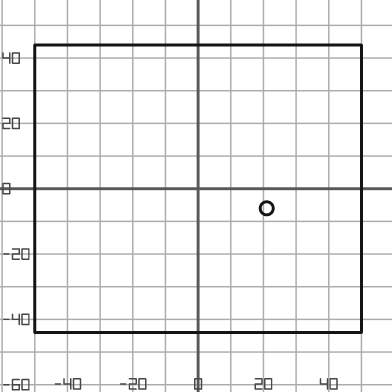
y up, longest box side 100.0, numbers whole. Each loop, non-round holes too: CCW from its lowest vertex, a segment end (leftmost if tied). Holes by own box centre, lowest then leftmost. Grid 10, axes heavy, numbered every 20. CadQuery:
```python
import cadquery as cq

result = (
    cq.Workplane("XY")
    .moveTo(-50.0, -44.0)
    .lineTo(50.0, -44.0)
    .lineTo(50.0, 44.0)
    .lineTo(-50.0, 44.0)
    .close()
    .moveTo(21.0, -6.0)
    .circle(2.0)
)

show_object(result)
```